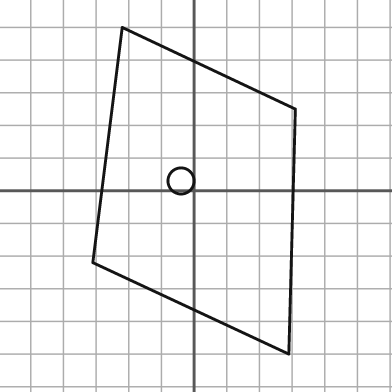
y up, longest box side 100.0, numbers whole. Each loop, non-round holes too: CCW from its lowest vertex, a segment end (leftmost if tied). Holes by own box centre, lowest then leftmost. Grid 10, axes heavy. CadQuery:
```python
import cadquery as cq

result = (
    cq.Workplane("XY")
    .moveTo(29.0, -50.0)
    .lineTo(31.0, 25.0)
    .lineTo(-22.0, 50.0)
    .lineTo(-31.0, -22.0)
    .close()
    .moveTo(-4.0, 3.0)
    .circle(4.0)
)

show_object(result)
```